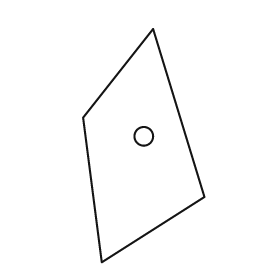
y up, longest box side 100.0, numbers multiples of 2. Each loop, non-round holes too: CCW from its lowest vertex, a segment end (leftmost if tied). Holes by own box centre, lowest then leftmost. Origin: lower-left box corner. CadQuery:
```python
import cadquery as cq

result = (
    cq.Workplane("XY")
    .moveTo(8.0, 0.0)
    .lineTo(52.0, 28.0)
    .lineTo(30.0, 100.0)
    .lineTo(0.0, 62.0)
    .close()
    .moveTo(26.0, 54.0)
    .circle(4.0)
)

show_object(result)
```